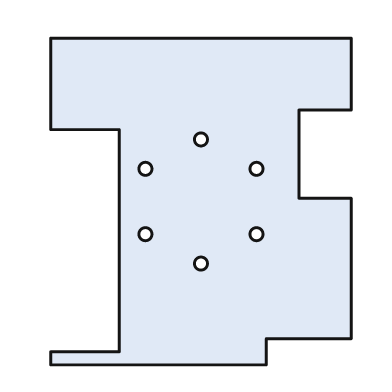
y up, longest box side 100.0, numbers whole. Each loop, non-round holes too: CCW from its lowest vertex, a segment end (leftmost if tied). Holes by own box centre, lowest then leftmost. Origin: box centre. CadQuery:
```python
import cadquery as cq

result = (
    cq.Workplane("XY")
    .moveTo(-46.0, -50.0)
    .lineTo(20.0, -50.0)
    .lineTo(20.0, -42.0)
    .lineTo(46.0, -42.0)
    .lineTo(46.0, 1.0)
    .lineTo(30.0, 1.0)
    .lineTo(30.0, 28.0)
    .lineTo(46.0, 28.0)
    .lineTo(46.0, 50.0)
    .lineTo(-46.0, 50.0)
    .lineTo(-46.0, 22.0)
    .lineTo(-25.0, 22.0)
    .lineTo(-25.0, -46.0)
    .lineTo(-46.0, -46.0)
    .close()
    .moveTo(0.0, -19.0)
    .circle(2.0)
    .moveTo(-17.0, -10.0)
    .circle(2.0)
    .moveTo(17.0, -10.0)
    .circle(2.0)
    .moveTo(-17.0, 10.0)
    .circle(2.0)
    .moveTo(17.0, 10.0)
    .circle(2.0)
    .moveTo(0.0, 19.0)
    .circle(2.0)
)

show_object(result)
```